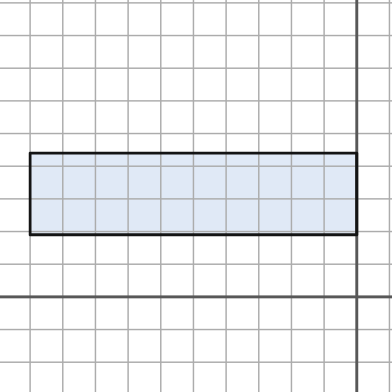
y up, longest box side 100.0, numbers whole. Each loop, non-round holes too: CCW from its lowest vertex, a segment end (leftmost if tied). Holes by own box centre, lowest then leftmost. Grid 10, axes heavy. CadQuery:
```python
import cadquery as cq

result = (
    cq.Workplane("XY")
    .moveTo(-100.0, 19.0)
    .lineTo(0.0, 19.0)
    .lineTo(0.0, 44.0)
    .lineTo(-100.0, 44.0)
    .close()
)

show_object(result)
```